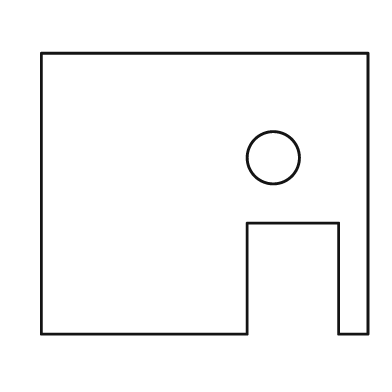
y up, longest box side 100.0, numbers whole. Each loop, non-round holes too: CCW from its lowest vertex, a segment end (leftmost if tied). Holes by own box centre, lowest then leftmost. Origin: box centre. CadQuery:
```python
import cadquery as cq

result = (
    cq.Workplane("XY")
    .moveTo(-50.0, -43.0)
    .lineTo(13.0, -43.0)
    .lineTo(13.0, -9.0)
    .lineTo(41.0, -9.0)
    .lineTo(41.0, -43.0)
    .lineTo(50.0, -43.0)
    .lineTo(50.0, 43.0)
    .lineTo(-50.0, 43.0)
    .close()
    .moveTo(21.0, 11.0)
    .circle(8.0)
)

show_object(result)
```